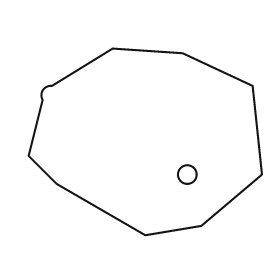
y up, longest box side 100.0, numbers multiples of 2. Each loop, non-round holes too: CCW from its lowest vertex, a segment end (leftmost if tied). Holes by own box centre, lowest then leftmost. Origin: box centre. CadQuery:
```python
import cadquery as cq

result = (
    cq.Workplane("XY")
    .moveTo(0.0, -40.0)
    .lineTo(24.0, -36.0)
    .lineTo(50.0, -14.0)
    .lineTo(46.0, 24.0)
    .lineTo(16.0, 38.0)
    .lineTo(-14.0, 40.0)
    .lineTo(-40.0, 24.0)
    .threePointArc((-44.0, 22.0), (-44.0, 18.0))
    .lineTo(-50.0, -6.0)
    .lineTo(-38.0, -18.0)
    .close()
    .moveTo(18.0, -14.0)
    .circle(4.0)
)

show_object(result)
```